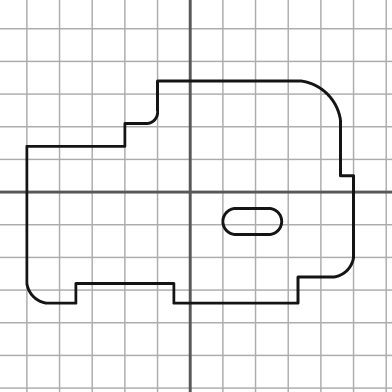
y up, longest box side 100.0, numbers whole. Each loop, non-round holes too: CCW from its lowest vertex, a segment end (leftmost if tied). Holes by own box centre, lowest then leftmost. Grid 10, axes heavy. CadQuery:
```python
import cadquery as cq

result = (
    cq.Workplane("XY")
    .moveTo(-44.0, -34.0)
    .lineTo(-35.0, -34.0)
    .lineTo(-35.0, -28.0)
    .lineTo(-5.0, -28.0)
    .lineTo(-5.0, -34.0)
    .lineTo(33.0, -34.0)
    .lineTo(33.0, -26.0)
    .lineTo(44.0, -26.0)
    .threePointArc((48.0, -24.0), (50.0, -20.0))
    .lineTo(50.0, 5.0)
    .lineTo(46.0, 5.0)
    .lineTo(46.0, 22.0)
    .threePointArc((42.0, 30.0), (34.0, 34.0))
    .lineTo(-10.0, 34.0)
    .lineTo(-10.0, 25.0)
    .threePointArc((-11.0, 22.0), (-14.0, 21.0))
    .lineTo(-20.0, 21.0)
    .lineTo(-20.0, 14.0)
    .lineTo(-50.0, 14.0)
    .lineTo(-50.0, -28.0)
    .threePointArc((-48.0, -32.0), (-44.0, -34.0))
    .close()
    .moveTo(14.0, -13.0)
    .lineTo(24.0, -13.0)
    .threePointArc((28.0, -9.0), (24.0, -5.0))
    .lineTo(14.0, -5.0)
    .threePointArc((10.0, -9.0), (14.0, -13.0))
    .close()
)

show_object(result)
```